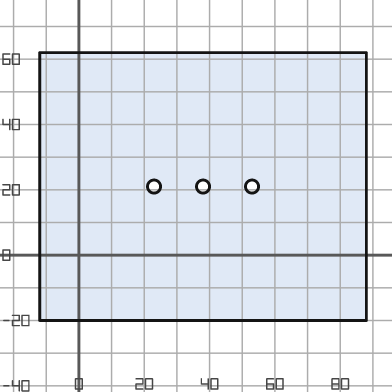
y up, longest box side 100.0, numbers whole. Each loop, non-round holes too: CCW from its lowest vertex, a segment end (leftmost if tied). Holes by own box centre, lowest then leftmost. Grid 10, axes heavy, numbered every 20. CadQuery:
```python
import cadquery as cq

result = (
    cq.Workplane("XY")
    .moveTo(-12.0, -20.0)
    .lineTo(88.0, -20.0)
    .lineTo(88.0, 62.0)
    .lineTo(-12.0, 62.0)
    .close()
    .moveTo(23.0, 21.0)
    .circle(2.0)
    .moveTo(38.0, 21.0)
    .circle(2.0)
    .moveTo(53.0, 21.0)
    .circle(2.0)
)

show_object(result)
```